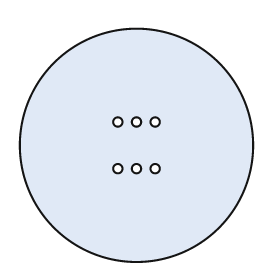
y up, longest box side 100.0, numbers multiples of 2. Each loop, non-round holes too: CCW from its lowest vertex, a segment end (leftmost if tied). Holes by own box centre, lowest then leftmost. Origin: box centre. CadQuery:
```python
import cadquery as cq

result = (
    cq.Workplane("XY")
    .moveTo(0.0, 0.0)
    .circle(50.0)
    .moveTo(-8.0, -10.0)
    .circle(2.0)
    .moveTo(0.0, -10.0)
    .circle(2.0)
    .moveTo(8.0, -10.0)
    .circle(2.0)
    .moveTo(-8.0, 10.0)
    .circle(2.0)
    .moveTo(0.0, 10.0)
    .circle(2.0)
    .moveTo(8.0, 10.0)
    .circle(2.0)
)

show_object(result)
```